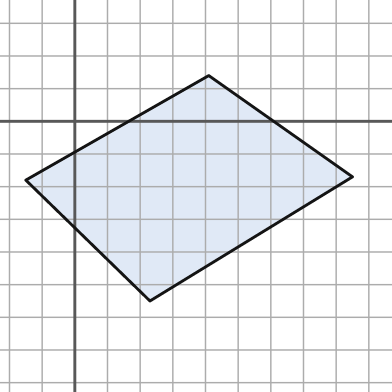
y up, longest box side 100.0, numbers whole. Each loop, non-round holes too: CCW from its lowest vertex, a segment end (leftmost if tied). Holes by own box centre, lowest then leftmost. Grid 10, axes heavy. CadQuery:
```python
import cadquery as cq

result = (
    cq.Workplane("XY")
    .moveTo(23.0, -55.0)
    .lineTo(85.0, -17.0)
    .lineTo(41.0, 14.0)
    .lineTo(-15.0, -18.0)
    .close()
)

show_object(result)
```